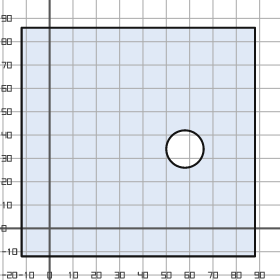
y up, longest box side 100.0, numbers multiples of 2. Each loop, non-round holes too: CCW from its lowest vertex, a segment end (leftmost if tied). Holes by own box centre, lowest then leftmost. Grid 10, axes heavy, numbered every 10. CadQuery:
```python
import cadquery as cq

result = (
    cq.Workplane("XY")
    .moveTo(-12.0, -12.0)
    .lineTo(88.0, -12.0)
    .lineTo(88.0, 86.0)
    .lineTo(-12.0, 86.0)
    .close()
    .moveTo(58.0, 34.0)
    .circle(8.0)
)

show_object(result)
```